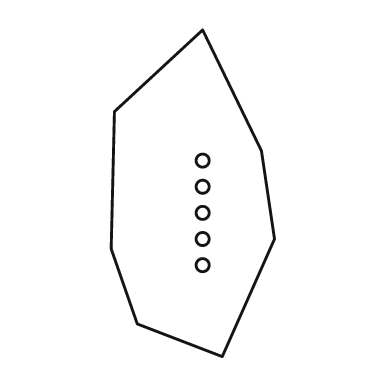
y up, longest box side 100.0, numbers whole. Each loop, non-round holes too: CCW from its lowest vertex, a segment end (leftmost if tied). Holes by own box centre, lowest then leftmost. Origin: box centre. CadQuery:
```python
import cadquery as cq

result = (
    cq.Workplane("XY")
    .moveTo(9.0, -50.0)
    .lineTo(25.0, -14.0)
    .lineTo(21.0, 13.0)
    .lineTo(3.0, 50.0)
    .lineTo(-24.0, 25.0)
    .lineTo(-25.0, -17.0)
    .lineTo(-17.0, -40.0)
    .close()
    .moveTo(3.0, -22.0)
    .circle(2.0)
    .moveTo(3.0, -14.0)
    .circle(2.0)
    .moveTo(3.0, -6.0)
    .circle(2.0)
    .moveTo(3.0, 2.0)
    .circle(2.0)
    .moveTo(3.0, 10.0)
    .circle(2.0)
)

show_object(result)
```